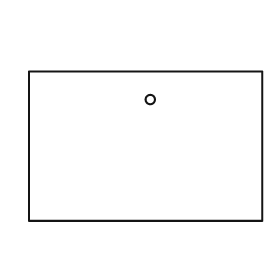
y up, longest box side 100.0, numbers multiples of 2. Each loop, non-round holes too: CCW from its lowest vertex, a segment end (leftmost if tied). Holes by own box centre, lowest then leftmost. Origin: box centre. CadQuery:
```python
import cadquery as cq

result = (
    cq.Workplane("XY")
    .moveTo(-50.0, -32.0)
    .lineTo(50.0, -32.0)
    .lineTo(50.0, 32.0)
    .lineTo(-50.0, 32.0)
    .close()
    .moveTo(2.0, 20.0)
    .circle(2.0)
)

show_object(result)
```